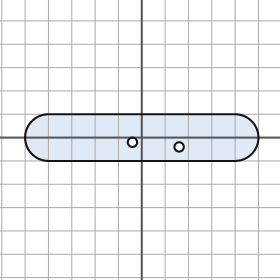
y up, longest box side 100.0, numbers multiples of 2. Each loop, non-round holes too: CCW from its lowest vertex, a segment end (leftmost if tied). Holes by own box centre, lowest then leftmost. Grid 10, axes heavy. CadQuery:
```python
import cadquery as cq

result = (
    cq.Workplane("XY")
    .moveTo(-40.0, -10.0)
    .lineTo(40.0, -10.0)
    .threePointArc((50.0, 0.0), (40.0, 10.0))
    .lineTo(-40.0, 10.0)
    .threePointArc((-50.0, 0.0), (-40.0, -10.0))
    .close()
    .moveTo(16.0, -4.0)
    .circle(2.0)
    .moveTo(-4.0, -2.0)
    .circle(2.0)
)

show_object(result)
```